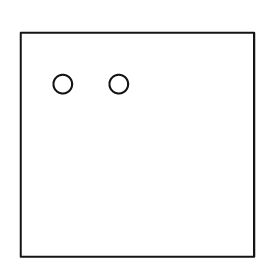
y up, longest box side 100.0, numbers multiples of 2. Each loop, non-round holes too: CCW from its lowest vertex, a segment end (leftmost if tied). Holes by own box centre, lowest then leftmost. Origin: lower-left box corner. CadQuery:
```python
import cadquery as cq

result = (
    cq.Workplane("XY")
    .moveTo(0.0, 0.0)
    .lineTo(100.0, 0.0)
    .lineTo(100.0, 96.0)
    .lineTo(0.0, 96.0)
    .close()
    .moveTo(18.0, 74.0)
    .circle(4.0)
    .moveTo(42.0, 74.0)
    .circle(4.0)
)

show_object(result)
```